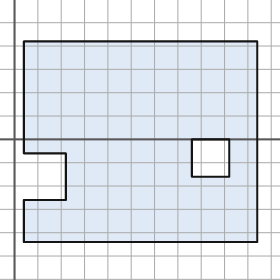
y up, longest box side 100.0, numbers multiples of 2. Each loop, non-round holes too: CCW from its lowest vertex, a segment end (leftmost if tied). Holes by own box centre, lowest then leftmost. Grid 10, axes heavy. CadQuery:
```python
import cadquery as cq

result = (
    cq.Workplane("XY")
    .moveTo(4.0, -44.0)
    .lineTo(104.0, -44.0)
    .lineTo(104.0, 42.0)
    .lineTo(4.0, 42.0)
    .lineTo(4.0, -6.0)
    .lineTo(22.0, -6.0)
    .lineTo(22.0, -26.0)
    .lineTo(4.0, -26.0)
    .close()
    .moveTo(76.0, -16.0)
    .lineTo(92.0, -16.0)
    .lineTo(92.0, 0.0)
    .lineTo(76.0, 0.0)
    .close()
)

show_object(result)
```